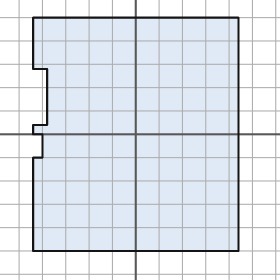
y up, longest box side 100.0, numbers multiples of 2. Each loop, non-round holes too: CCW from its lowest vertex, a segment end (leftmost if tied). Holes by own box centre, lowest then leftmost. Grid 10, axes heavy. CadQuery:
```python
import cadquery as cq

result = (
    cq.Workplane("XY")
    .moveTo(-44.0, -50.0)
    .lineTo(44.0, -50.0)
    .lineTo(44.0, 50.0)
    .lineTo(-44.0, 50.0)
    .lineTo(-44.0, 28.0)
    .lineTo(-38.0, 28.0)
    .lineTo(-38.0, 4.0)
    .lineTo(-44.0, 4.0)
    .lineTo(-44.0, 0.0)
    .lineTo(-40.0, 0.0)
    .lineTo(-40.0, -10.0)
    .lineTo(-44.0, -10.0)
    .close()
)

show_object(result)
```